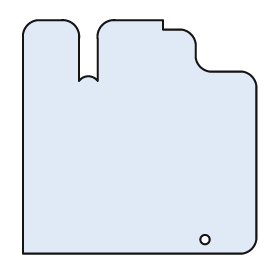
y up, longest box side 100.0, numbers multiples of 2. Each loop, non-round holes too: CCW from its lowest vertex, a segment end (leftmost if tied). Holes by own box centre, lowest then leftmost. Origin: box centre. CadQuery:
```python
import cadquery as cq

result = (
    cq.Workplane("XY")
    .moveTo(-50.0, -50.0)
    .lineTo(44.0, -50.0)
    .threePointArc((48.0, -48.0), (50.0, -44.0))
    .lineTo(50.0, 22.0)
    .threePointArc((48.0, 26.0), (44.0, 28.0))
    .lineTo(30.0, 28.0)
    .threePointArc((26.0, 30.0), (24.0, 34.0))
    .lineTo(24.0, 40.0)
    .threePointArc((22.0, 44.0), (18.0, 46.0))
    .lineTo(10.0, 46.0)
    .lineTo(10.0, 50.0)
    .lineTo(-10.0, 50.0)
    .threePointArc((-16.0, 48.0), (-18.0, 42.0))
    .lineTo(-18.0, 24.0)
    .threePointArc((-22.0, 26.0), (-26.0, 24.0))
    .lineTo(-26.0, 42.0)
    .threePointArc((-28.0, 48.0), (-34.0, 50.0))
    .lineTo(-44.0, 50.0)
    .threePointArc((-48.0, 48.0), (-50.0, 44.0))
    .close()
    .moveTo(28.0, -44.0)
    .circle(2.0)
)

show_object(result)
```